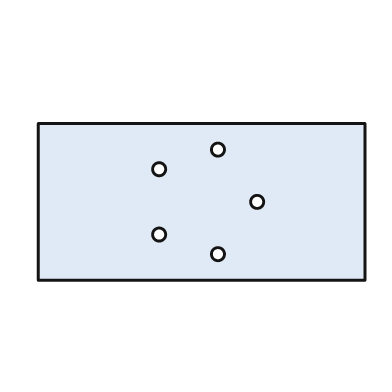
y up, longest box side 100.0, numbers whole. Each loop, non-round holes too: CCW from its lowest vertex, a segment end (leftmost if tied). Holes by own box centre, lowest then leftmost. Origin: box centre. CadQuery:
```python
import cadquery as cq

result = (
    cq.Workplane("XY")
    .moveTo(-50.0, -24.0)
    .lineTo(50.0, -24.0)
    .lineTo(50.0, 24.0)
    .lineTo(-50.0, 24.0)
    .close()
    .moveTo(5.0, -16.0)
    .circle(2.0)
    .moveTo(-13.0, -10.0)
    .circle(2.0)
    .moveTo(17.0, 0.0)
    .circle(2.0)
    .moveTo(-13.0, 10.0)
    .circle(2.0)
    .moveTo(5.0, 16.0)
    .circle(2.0)
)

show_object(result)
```